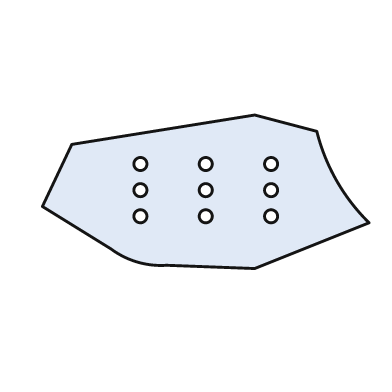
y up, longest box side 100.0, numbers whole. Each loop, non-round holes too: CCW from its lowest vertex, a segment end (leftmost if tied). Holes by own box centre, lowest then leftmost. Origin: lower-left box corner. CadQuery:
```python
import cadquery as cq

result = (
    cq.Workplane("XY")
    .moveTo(65.0, 0.0)
    .lineTo(100.0, 14.0)
    .threePointArc((90.0, 27.0), (84.0, 42.0))
    .lineTo(65.0, 47.0)
    .lineTo(9.0, 38.0)
    .lineTo(0.0, 19.0)
    .lineTo(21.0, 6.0)
    .threePointArc((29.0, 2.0), (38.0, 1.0))
    .close()
    .moveTo(30.0, 16.0)
    .circle(2.0)
    .moveTo(50.0, 16.0)
    .circle(2.0)
    .moveTo(70.0, 16.0)
    .circle(2.0)
    .moveTo(30.0, 24.0)
    .circle(2.0)
    .moveTo(50.0, 24.0)
    .circle(2.0)
    .moveTo(70.0, 24.0)
    .circle(2.0)
    .moveTo(30.0, 32.0)
    .circle(2.0)
    .moveTo(50.0, 32.0)
    .circle(2.0)
    .moveTo(70.0, 32.0)
    .circle(2.0)
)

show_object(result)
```